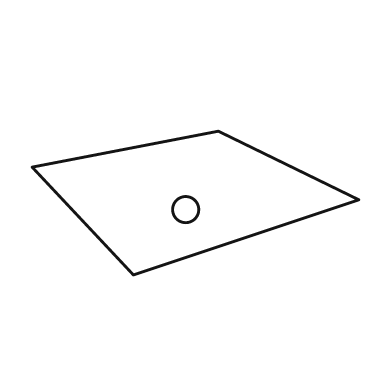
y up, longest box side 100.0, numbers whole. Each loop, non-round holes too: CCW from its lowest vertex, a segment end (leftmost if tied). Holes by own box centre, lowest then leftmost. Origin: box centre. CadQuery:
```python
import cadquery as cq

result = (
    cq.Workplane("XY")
    .moveTo(-19.0, -22.0)
    .lineTo(50.0, 1.0)
    .lineTo(7.0, 22.0)
    .lineTo(-50.0, 11.0)
    .close()
    .moveTo(-3.0, -2.0)
    .circle(4.0)
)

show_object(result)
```